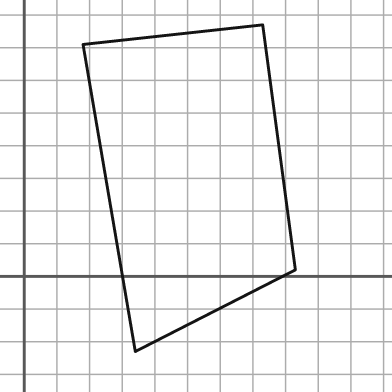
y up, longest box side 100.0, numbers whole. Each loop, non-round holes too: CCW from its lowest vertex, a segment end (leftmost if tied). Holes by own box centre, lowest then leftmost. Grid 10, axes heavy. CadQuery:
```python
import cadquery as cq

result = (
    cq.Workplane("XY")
    .moveTo(34.0, -23.0)
    .lineTo(83.0, 2.0)
    .lineTo(73.0, 77.0)
    .lineTo(18.0, 71.0)
    .close()
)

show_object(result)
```